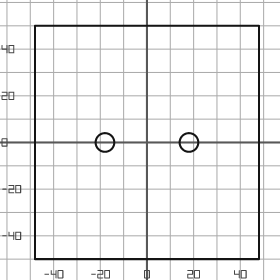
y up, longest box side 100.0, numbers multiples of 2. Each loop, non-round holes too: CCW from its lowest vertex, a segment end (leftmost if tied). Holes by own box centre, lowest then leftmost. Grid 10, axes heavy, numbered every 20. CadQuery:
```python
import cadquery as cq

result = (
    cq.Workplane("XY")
    .moveTo(-48.0, -50.0)
    .lineTo(48.0, -50.0)
    .lineTo(48.0, 50.0)
    .lineTo(-48.0, 50.0)
    .close()
    .moveTo(-18.0, 0.0)
    .circle(4.0)
    .moveTo(18.0, 0.0)
    .circle(4.0)
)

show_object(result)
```